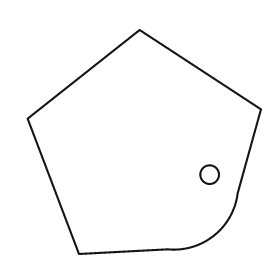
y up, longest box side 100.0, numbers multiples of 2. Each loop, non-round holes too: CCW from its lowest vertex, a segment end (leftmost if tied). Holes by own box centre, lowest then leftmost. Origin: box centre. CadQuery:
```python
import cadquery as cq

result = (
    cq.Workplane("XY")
    .moveTo(-28.0, -48.0)
    .lineTo(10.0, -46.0)
    .threePointArc((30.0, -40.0), (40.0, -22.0))
    .lineTo(50.0, 14.0)
    .lineTo(-2.0, 48.0)
    .lineTo(-50.0, 10.0)
    .close()
    .moveTo(28.0, -14.0)
    .circle(4.0)
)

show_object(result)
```